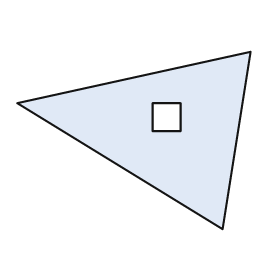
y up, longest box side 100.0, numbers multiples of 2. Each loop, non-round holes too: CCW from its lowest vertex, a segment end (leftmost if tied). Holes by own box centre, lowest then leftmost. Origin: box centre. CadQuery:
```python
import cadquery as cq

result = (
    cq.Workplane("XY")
    .moveTo(38.0, -38.0)
    .lineTo(50.0, 38.0)
    .lineTo(-50.0, 16.0)
    .close()
    .moveTo(8.0, 4.0)
    .lineTo(20.0, 4.0)
    .lineTo(20.0, 16.0)
    .lineTo(8.0, 16.0)
    .close()
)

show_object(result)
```